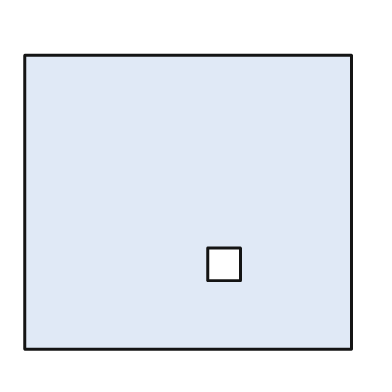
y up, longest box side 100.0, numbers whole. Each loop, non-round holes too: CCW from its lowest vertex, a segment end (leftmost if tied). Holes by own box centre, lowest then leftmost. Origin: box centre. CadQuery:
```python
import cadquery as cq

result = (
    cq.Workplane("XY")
    .moveTo(-50.0, -45.0)
    .lineTo(50.0, -45.0)
    .lineTo(50.0, 45.0)
    .lineTo(-50.0, 45.0)
    .close()
    .moveTo(6.0, -24.0)
    .lineTo(16.0, -24.0)
    .lineTo(16.0, -14.0)
    .lineTo(6.0, -14.0)
    .close()
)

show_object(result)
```